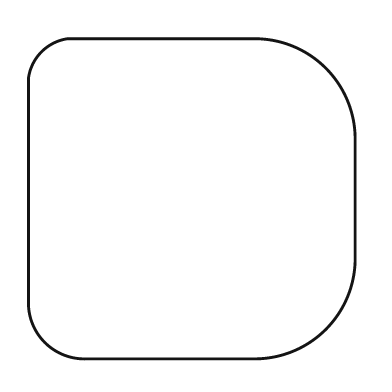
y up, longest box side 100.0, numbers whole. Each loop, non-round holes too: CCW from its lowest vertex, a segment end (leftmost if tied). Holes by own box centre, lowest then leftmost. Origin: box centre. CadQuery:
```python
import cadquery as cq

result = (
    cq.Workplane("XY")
    .moveTo(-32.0, -49.0)
    .lineTo(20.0, -49.0)
    .threePointArc((41.0, -40.0), (50.0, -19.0))
    .lineTo(50.0, 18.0)
    .threePointArc((41.0, 40.0), (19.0, 49.0))
    .lineTo(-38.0, 49.0)
    .threePointArc((-46.0, 45.0), (-50.0, 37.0))
    .lineTo(-50.0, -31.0)
    .threePointArc((-45.0, -44.0), (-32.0, -49.0))
    .close()
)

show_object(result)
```